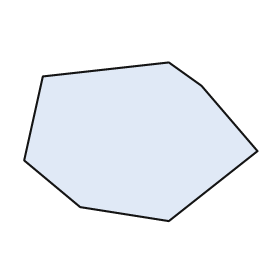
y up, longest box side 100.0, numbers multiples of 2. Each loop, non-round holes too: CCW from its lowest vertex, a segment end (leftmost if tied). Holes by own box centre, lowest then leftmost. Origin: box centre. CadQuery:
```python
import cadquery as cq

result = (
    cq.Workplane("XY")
    .moveTo(12.0, -34.0)
    .lineTo(50.0, -4.0)
    .lineTo(26.0, 24.0)
    .lineTo(12.0, 34.0)
    .lineTo(-42.0, 28.0)
    .lineTo(-50.0, -8.0)
    .lineTo(-26.0, -28.0)
    .close()
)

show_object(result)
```